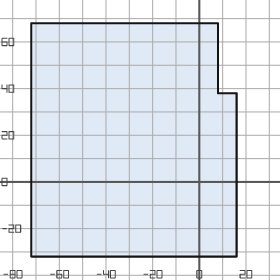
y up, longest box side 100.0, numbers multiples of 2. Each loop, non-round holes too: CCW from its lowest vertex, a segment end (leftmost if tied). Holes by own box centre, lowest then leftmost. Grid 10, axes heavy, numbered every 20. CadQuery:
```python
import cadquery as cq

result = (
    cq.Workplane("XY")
    .moveTo(-72.0, -32.0)
    .lineTo(16.0, -32.0)
    .lineTo(16.0, 38.0)
    .lineTo(8.0, 38.0)
    .lineTo(8.0, 68.0)
    .lineTo(-72.0, 68.0)
    .close()
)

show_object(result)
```